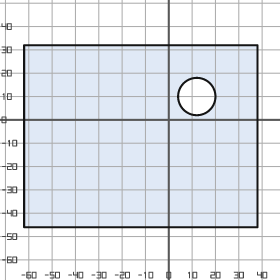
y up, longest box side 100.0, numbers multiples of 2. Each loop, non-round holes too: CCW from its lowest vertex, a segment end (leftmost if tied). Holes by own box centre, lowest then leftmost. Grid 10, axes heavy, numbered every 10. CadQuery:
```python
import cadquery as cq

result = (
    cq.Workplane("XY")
    .moveTo(-62.0, -46.0)
    .lineTo(38.0, -46.0)
    .lineTo(38.0, 32.0)
    .lineTo(-62.0, 32.0)
    .close()
    .moveTo(12.0, 10.0)
    .circle(8.0)
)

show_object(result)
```